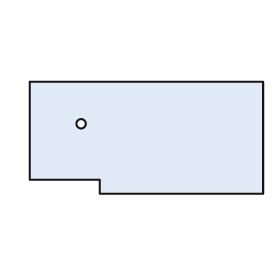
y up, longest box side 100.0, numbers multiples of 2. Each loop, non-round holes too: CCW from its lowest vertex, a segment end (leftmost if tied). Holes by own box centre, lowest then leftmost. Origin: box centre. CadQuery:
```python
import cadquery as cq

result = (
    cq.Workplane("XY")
    .moveTo(-20.0, -24.0)
    .lineTo(50.0, -24.0)
    .lineTo(50.0, 24.0)
    .lineTo(-50.0, 24.0)
    .lineTo(-50.0, -18.0)
    .lineTo(-20.0, -18.0)
    .close()
    .moveTo(-28.0, 6.0)
    .circle(2.0)
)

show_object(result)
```